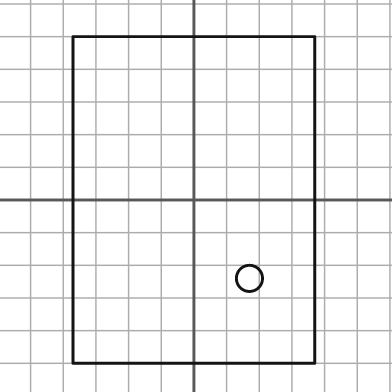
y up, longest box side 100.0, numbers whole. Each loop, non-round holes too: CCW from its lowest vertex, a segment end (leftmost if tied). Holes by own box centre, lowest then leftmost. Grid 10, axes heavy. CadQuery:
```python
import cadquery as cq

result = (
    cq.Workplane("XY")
    .moveTo(-37.0, -50.0)
    .lineTo(37.0, -50.0)
    .lineTo(37.0, 50.0)
    .lineTo(-37.0, 50.0)
    .close()
    .moveTo(17.0, -24.0)
    .circle(4.0)
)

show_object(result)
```